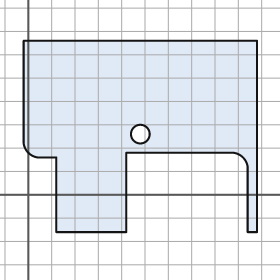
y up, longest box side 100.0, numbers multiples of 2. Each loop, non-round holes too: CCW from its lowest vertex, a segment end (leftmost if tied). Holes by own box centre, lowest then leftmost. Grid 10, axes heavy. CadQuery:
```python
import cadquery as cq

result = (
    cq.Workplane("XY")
    .moveTo(12.0, -16.0)
    .lineTo(42.0, -16.0)
    .lineTo(42.0, 18.0)
    .lineTo(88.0, 18.0)
    .threePointArc((92.0, 16.0), (94.0, 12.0))
    .lineTo(94.0, -16.0)
    .lineTo(98.0, -16.0)
    .lineTo(98.0, 66.0)
    .lineTo(-2.0, 66.0)
    .lineTo(-2.0, 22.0)
    .threePointArc((0.0, 18.0), (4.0, 16.0))
    .lineTo(12.0, 16.0)
    .close()
    .moveTo(48.0, 26.0)
    .circle(4.0)
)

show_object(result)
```